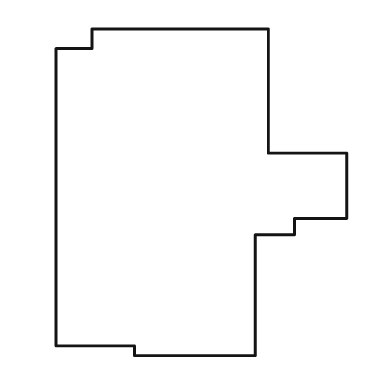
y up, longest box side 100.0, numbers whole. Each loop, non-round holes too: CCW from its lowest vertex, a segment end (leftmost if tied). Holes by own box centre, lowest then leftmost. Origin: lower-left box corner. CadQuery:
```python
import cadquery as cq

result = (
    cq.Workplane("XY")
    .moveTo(24.0, 0.0)
    .lineTo(61.0, 0.0)
    .lineTo(61.0, 37.0)
    .lineTo(73.0, 37.0)
    .lineTo(73.0, 42.0)
    .lineTo(89.0, 42.0)
    .lineTo(89.0, 62.0)
    .lineTo(65.0, 62.0)
    .lineTo(65.0, 100.0)
    .lineTo(11.0, 100.0)
    .lineTo(11.0, 94.0)
    .lineTo(0.0, 94.0)
    .lineTo(0.0, 3.0)
    .lineTo(24.0, 3.0)
    .close()
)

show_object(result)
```